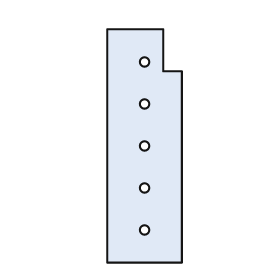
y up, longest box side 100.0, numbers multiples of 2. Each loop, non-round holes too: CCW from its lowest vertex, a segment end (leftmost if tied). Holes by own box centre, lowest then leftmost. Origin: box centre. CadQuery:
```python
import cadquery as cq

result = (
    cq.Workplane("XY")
    .moveTo(-16.0, -50.0)
    .lineTo(16.0, -50.0)
    .lineTo(16.0, 32.0)
    .lineTo(8.0, 32.0)
    .lineTo(8.0, 50.0)
    .lineTo(-16.0, 50.0)
    .close()
    .moveTo(0.0, -36.0)
    .circle(2.0)
    .moveTo(0.0, -18.0)
    .circle(2.0)
    .moveTo(0.0, 0.0)
    .circle(2.0)
    .moveTo(0.0, 18.0)
    .circle(2.0)
    .moveTo(0.0, 36.0)
    .circle(2.0)
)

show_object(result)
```